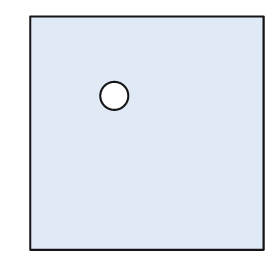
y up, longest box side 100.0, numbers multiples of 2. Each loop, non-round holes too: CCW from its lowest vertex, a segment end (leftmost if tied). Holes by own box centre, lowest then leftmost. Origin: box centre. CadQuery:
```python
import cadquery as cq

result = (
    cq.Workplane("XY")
    .moveTo(-50.0, -50.0)
    .lineTo(50.0, -50.0)
    .lineTo(50.0, 50.0)
    .lineTo(-50.0, 50.0)
    .close()
    .moveTo(-14.0, 16.0)
    .circle(6.0)
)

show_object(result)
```